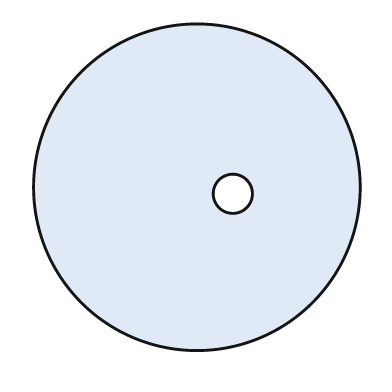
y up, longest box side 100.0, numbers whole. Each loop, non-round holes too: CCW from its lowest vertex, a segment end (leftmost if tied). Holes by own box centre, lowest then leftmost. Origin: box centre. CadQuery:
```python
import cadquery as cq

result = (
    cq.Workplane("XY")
    .moveTo(0.0, 0.0)
    .circle(50.0)
    .moveTo(11.0, -2.0)
    .circle(6.0)
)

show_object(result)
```